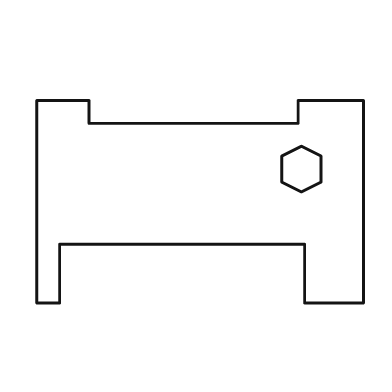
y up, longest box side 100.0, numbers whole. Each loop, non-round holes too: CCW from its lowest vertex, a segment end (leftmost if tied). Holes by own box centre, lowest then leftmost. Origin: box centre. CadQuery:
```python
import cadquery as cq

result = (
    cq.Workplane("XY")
    .moveTo(-50.0, -31.0)
    .lineTo(-43.0, -31.0)
    .lineTo(-43.0, -13.0)
    .lineTo(32.0, -13.0)
    .lineTo(32.0, -31.0)
    .lineTo(50.0, -31.0)
    .lineTo(50.0, 31.0)
    .lineTo(30.0, 31.0)
    .lineTo(30.0, 24.0)
    .lineTo(-34.0, 24.0)
    .lineTo(-34.0, 31.0)
    .lineTo(-50.0, 31.0)
    .close()
    .moveTo(31.0, 3.0)
    .lineTo(37.0, 6.0)
    .lineTo(37.0, 14.0)
    .lineTo(31.0, 17.0)
    .lineTo(25.0, 14.0)
    .lineTo(25.0, 6.0)
    .close()
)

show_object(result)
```